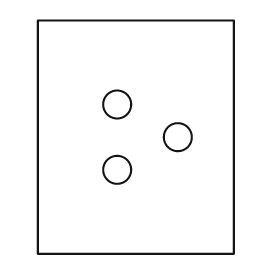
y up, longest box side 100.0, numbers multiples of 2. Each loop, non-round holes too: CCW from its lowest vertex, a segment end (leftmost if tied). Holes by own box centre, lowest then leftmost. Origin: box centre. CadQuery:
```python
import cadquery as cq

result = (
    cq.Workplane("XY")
    .moveTo(-42.0, -50.0)
    .lineTo(42.0, -50.0)
    .lineTo(42.0, 50.0)
    .lineTo(-42.0, 50.0)
    .close()
    .moveTo(-8.0, -14.0)
    .circle(6.0)
    .moveTo(18.0, 0.0)
    .circle(6.0)
    .moveTo(-8.0, 14.0)
    .circle(6.0)
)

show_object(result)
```